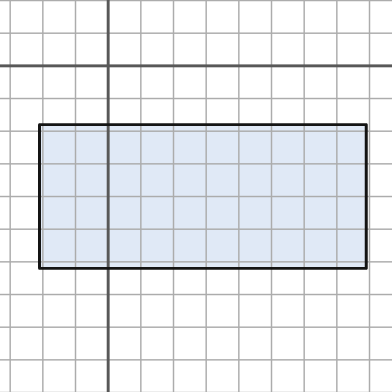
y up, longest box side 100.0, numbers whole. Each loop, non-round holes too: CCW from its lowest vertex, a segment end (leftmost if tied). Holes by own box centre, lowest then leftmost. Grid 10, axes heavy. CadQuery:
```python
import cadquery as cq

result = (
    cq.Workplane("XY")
    .moveTo(-21.0, -62.0)
    .lineTo(79.0, -62.0)
    .lineTo(79.0, -18.0)
    .lineTo(-21.0, -18.0)
    .close()
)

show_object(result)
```